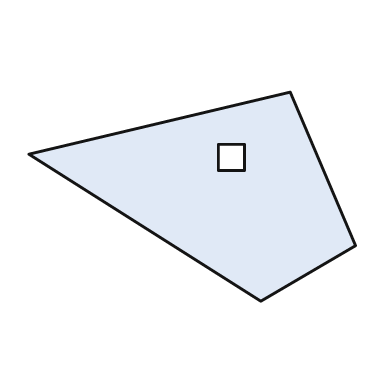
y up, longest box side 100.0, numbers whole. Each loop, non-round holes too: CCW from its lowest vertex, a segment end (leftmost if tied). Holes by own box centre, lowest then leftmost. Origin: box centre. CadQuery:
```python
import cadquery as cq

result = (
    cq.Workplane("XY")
    .moveTo(21.0, -32.0)
    .lineTo(50.0, -15.0)
    .lineTo(30.0, 32.0)
    .lineTo(-50.0, 13.0)
    .close()
    .moveTo(8.0, 8.0)
    .lineTo(16.0, 8.0)
    .lineTo(16.0, 16.0)
    .lineTo(8.0, 16.0)
    .close()
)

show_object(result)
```